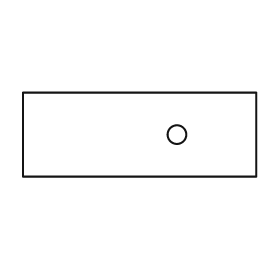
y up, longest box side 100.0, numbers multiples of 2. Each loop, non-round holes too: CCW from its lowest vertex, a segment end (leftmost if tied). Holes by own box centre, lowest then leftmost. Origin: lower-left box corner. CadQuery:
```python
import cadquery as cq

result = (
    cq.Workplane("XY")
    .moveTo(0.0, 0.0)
    .lineTo(100.0, 0.0)
    .lineTo(100.0, 36.0)
    .lineTo(0.0, 36.0)
    .close()
    .moveTo(66.0, 18.0)
    .circle(4.0)
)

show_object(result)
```